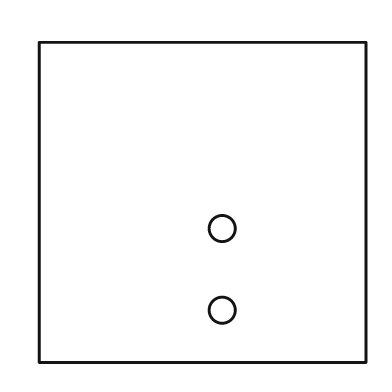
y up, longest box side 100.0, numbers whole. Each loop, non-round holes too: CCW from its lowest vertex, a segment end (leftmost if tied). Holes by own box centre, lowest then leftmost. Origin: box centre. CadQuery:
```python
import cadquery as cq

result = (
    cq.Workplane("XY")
    .moveTo(-50.0, -49.0)
    .lineTo(50.0, -49.0)
    .lineTo(50.0, 49.0)
    .lineTo(-50.0, 49.0)
    .close()
    .moveTo(6.0, -33.0)
    .circle(4.0)
    .moveTo(6.0, -8.0)
    .circle(4.0)
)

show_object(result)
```